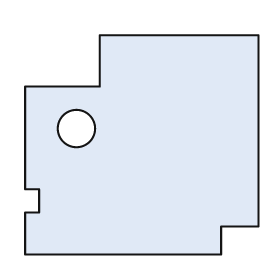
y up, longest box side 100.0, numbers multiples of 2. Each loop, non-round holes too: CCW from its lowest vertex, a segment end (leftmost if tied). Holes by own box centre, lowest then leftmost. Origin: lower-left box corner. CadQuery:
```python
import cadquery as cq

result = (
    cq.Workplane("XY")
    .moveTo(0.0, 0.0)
    .lineTo(84.0, 0.0)
    .lineTo(84.0, 12.0)
    .lineTo(100.0, 12.0)
    .lineTo(100.0, 94.0)
    .lineTo(32.0, 94.0)
    .lineTo(32.0, 72.0)
    .lineTo(0.0, 72.0)
    .lineTo(0.0, 28.0)
    .lineTo(6.0, 28.0)
    .lineTo(6.0, 18.0)
    .lineTo(0.0, 18.0)
    .close()
    .moveTo(22.0, 54.0)
    .circle(8.0)
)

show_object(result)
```